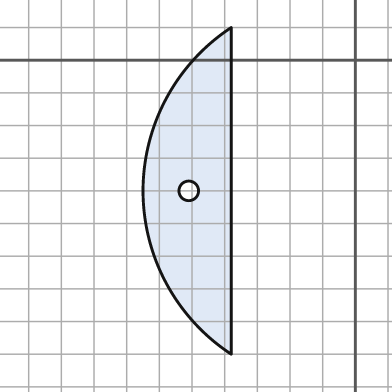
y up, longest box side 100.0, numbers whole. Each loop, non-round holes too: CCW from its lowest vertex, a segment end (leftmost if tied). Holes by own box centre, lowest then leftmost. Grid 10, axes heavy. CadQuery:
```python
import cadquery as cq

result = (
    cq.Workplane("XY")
    .moveTo(-38.0, -90.0)
    .lineTo(-38.0, 10.0)
    .threePointArc((-65.0, -40.0), (-38.0, -90.0))
    .close()
    .moveTo(-51.0, -40.0)
    .circle(3.0)
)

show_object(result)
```